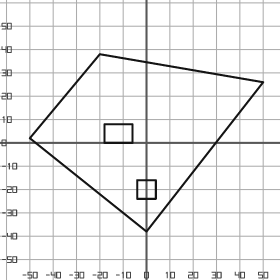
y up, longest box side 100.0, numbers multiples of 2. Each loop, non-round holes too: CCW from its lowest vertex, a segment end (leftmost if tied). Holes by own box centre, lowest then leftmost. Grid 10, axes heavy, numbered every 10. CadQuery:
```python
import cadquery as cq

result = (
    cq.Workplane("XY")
    .moveTo(0.0, -38.0)
    .lineTo(50.0, 26.0)
    .lineTo(-20.0, 38.0)
    .lineTo(-50.0, 2.0)
    .close()
    .moveTo(-4.0, -24.0)
    .lineTo(4.0, -24.0)
    .lineTo(4.0, -16.0)
    .lineTo(-4.0, -16.0)
    .close()
    .moveTo(-18.0, 0.0)
    .lineTo(-6.0, 0.0)
    .lineTo(-6.0, 8.0)
    .lineTo(-18.0, 8.0)
    .close()
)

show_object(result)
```